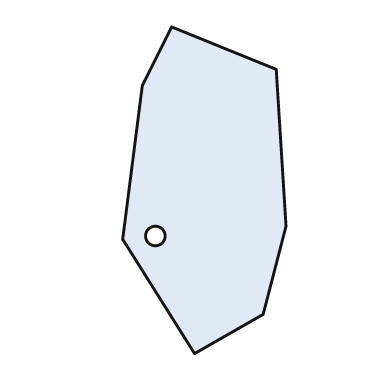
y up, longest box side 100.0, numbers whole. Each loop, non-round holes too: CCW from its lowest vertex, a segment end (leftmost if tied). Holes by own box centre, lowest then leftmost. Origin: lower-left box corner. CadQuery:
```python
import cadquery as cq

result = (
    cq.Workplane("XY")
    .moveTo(22.0, 0.0)
    .lineTo(43.0, 12.0)
    .lineTo(50.0, 39.0)
    .lineTo(47.0, 87.0)
    .lineTo(15.0, 100.0)
    .lineTo(6.0, 82.0)
    .lineTo(0.0, 35.0)
    .close()
    .moveTo(10.0, 36.0)
    .circle(3.0)
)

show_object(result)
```